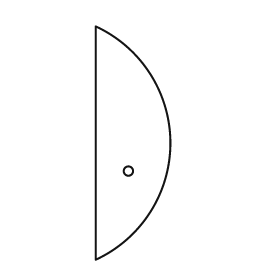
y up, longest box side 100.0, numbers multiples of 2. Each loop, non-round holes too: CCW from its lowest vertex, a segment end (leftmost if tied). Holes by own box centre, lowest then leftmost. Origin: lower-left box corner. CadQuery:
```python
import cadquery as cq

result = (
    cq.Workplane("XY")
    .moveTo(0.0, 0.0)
    .threePointArc((32.0, 50.0), (0.0, 100.0))
    .close()
    .moveTo(14.0, 38.0)
    .circle(2.0)
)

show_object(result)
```